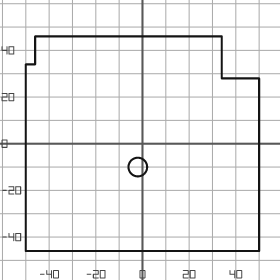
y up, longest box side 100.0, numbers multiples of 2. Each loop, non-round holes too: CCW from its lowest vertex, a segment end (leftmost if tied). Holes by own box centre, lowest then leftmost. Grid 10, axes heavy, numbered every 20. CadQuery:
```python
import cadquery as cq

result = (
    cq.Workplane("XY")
    .moveTo(-50.0, -46.0)
    .lineTo(50.0, -46.0)
    .lineTo(50.0, 28.0)
    .lineTo(34.0, 28.0)
    .lineTo(34.0, 46.0)
    .lineTo(-46.0, 46.0)
    .lineTo(-46.0, 34.0)
    .lineTo(-50.0, 34.0)
    .close()
    .moveTo(-2.0, -10.0)
    .circle(4.0)
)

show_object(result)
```